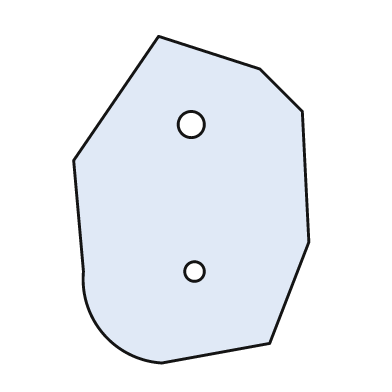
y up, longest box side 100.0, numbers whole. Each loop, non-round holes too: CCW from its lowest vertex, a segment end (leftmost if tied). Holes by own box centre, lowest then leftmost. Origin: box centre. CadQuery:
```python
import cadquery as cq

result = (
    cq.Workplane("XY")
    .moveTo(-9.0, -50.0)
    .lineTo(24.0, -44.0)
    .lineTo(36.0, -13.0)
    .lineTo(34.0, 27.0)
    .lineTo(21.0, 40.0)
    .lineTo(-10.0, 50.0)
    .lineTo(-36.0, 12.0)
    .lineTo(-33.0, -22.0)
    .threePointArc((-27.0, -41.0), (-9.0, -50.0))
    .close()
    .moveTo(1.0, -22.0)
    .circle(3.0)
    .moveTo(0.0, 23.0)
    .circle(4.0)
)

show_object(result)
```